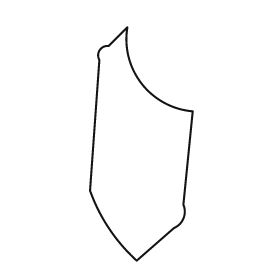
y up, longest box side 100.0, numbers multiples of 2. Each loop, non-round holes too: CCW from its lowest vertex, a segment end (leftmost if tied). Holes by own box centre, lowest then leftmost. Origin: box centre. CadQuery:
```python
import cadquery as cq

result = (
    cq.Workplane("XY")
    .moveTo(-2.0, -50.0)
    .lineTo(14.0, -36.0)
    .threePointArc((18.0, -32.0), (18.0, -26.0))
    .lineTo(22.0, 14.0)
    .threePointArc((0.0, 26.0), (-6.0, 50.0))
    .lineTo(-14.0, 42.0)
    .threePointArc((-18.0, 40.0), (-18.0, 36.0))
    .lineTo(-22.0, -20.0)
    .threePointArc((-14.0, -36.0), (-2.0, -50.0))
    .close()
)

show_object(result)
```